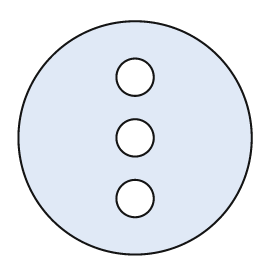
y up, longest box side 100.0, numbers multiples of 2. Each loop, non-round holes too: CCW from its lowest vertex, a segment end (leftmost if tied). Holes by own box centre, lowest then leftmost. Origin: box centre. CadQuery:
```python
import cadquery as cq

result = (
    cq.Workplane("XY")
    .moveTo(0.0, 0.0)
    .circle(50.0)
    .moveTo(0.0, -26.0)
    .circle(8.0)
    .moveTo(0.0, 0.0)
    .circle(8.0)
    .moveTo(0.0, 26.0)
    .circle(8.0)
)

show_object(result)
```